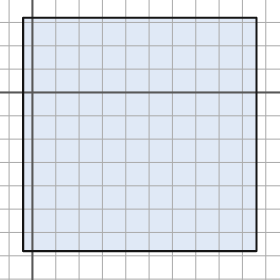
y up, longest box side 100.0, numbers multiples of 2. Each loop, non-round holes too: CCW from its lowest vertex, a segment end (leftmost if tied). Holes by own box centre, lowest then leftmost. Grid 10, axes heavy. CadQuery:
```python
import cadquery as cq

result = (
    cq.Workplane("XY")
    .moveTo(-4.0, -68.0)
    .lineTo(96.0, -68.0)
    .lineTo(96.0, 32.0)
    .lineTo(-4.0, 32.0)
    .close()
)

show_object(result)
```